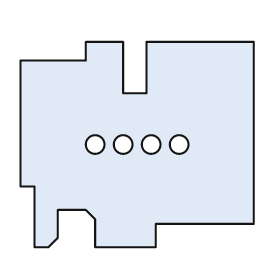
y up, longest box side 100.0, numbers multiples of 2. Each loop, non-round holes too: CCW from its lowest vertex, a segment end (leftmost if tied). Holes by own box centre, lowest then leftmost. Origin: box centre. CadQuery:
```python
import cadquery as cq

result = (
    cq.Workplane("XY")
    .moveTo(-44.0, -44.0)
    .lineTo(-38.0, -44.0)
    .lineTo(-34.0, -40.0)
    .lineTo(-34.0, -28.0)
    .lineTo(-22.0, -28.0)
    .lineTo(-18.0, -32.0)
    .lineTo(-18.0, -44.0)
    .lineTo(8.0, -44.0)
    .lineTo(8.0, -34.0)
    .lineTo(50.0, -34.0)
    .lineTo(50.0, 44.0)
    .lineTo(4.0, 44.0)
    .lineTo(4.0, 22.0)
    .lineTo(-6.0, 22.0)
    .lineTo(-6.0, 44.0)
    .lineTo(-22.0, 44.0)
    .lineTo(-22.0, 36.0)
    .lineTo(-50.0, 36.0)
    .lineTo(-50.0, -18.0)
    .lineTo(-44.0, -18.0)
    .close()
    .moveTo(-18.0, 0.0)
    .circle(4.0)
    .moveTo(-6.0, 0.0)
    .circle(4.0)
    .moveTo(6.0, 0.0)
    .circle(4.0)
    .moveTo(18.0, 0.0)
    .circle(4.0)
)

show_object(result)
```